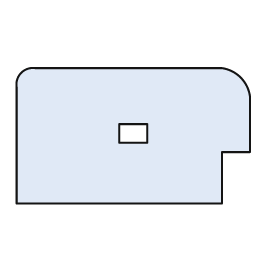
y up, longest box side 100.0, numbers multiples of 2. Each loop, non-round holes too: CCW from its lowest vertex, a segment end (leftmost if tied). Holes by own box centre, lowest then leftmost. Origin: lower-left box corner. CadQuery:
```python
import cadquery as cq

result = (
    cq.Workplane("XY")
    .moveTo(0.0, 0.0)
    .lineTo(88.0, 0.0)
    .lineTo(88.0, 22.0)
    .lineTo(100.0, 22.0)
    .lineTo(100.0, 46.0)
    .threePointArc((96.0, 54.0), (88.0, 58.0))
    .lineTo(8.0, 58.0)
    .threePointArc((2.0, 56.0), (0.0, 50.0))
    .close()
    .moveTo(44.0, 26.0)
    .lineTo(56.0, 26.0)
    .lineTo(56.0, 34.0)
    .lineTo(44.0, 34.0)
    .close()
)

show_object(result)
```